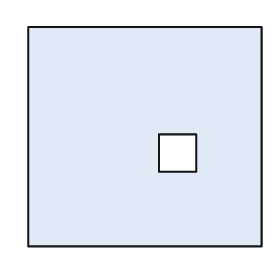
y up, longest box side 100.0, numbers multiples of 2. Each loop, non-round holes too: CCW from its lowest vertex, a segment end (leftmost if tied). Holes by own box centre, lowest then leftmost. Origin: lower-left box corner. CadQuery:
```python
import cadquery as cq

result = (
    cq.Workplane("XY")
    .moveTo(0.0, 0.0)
    .lineTo(100.0, 0.0)
    .lineTo(100.0, 94.0)
    .lineTo(0.0, 94.0)
    .close()
    .moveTo(56.0, 32.0)
    .lineTo(72.0, 32.0)
    .lineTo(72.0, 48.0)
    .lineTo(56.0, 48.0)
    .close()
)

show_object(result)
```